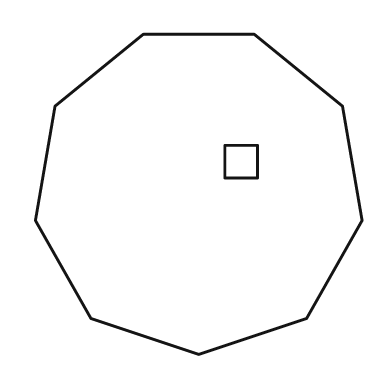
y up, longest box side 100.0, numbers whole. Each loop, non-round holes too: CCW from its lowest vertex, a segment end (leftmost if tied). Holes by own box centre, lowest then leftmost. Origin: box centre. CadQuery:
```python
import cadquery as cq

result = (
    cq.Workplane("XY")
    .moveTo(0.0, -49.0)
    .lineTo(33.0, -38.0)
    .lineTo(50.0, -8.0)
    .lineTo(44.0, 27.0)
    .lineTo(17.0, 49.0)
    .lineTo(-17.0, 49.0)
    .lineTo(-44.0, 27.0)
    .lineTo(-50.0, -8.0)
    .lineTo(-33.0, -38.0)
    .close()
    .moveTo(8.0, 5.0)
    .lineTo(18.0, 5.0)
    .lineTo(18.0, 15.0)
    .lineTo(8.0, 15.0)
    .close()
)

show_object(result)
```